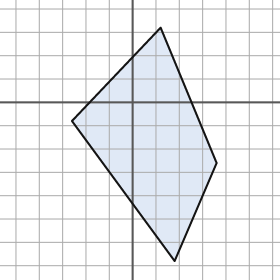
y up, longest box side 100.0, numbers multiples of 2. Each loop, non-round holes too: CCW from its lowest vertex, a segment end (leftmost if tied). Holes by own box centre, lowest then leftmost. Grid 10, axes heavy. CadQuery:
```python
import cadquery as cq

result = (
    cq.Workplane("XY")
    .moveTo(18.0, -68.0)
    .lineTo(36.0, -26.0)
    .lineTo(12.0, 32.0)
    .lineTo(-26.0, -8.0)
    .close()
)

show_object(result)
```